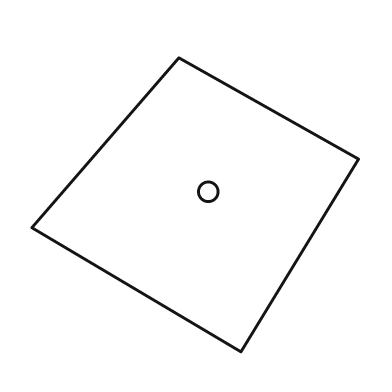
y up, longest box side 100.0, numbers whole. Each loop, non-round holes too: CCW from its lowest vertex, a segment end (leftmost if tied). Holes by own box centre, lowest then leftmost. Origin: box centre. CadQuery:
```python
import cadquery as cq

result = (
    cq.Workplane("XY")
    .moveTo(14.0, -45.0)
    .lineTo(50.0, 14.0)
    .lineTo(-5.0, 45.0)
    .lineTo(-50.0, -7.0)
    .close()
    .moveTo(4.0, 4.0)
    .circle(3.0)
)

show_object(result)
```